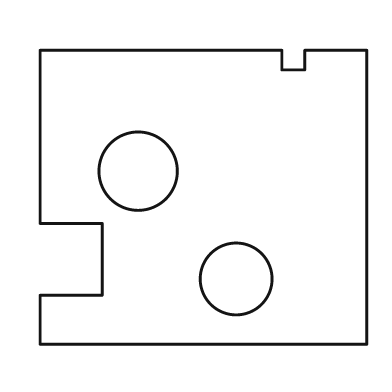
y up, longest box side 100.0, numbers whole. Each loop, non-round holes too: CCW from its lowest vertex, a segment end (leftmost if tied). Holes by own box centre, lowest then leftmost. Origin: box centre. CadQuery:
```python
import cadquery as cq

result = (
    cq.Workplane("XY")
    .moveTo(-50.0, -45.0)
    .lineTo(50.0, -45.0)
    .lineTo(50.0, 45.0)
    .lineTo(31.0, 45.0)
    .lineTo(31.0, 39.0)
    .lineTo(24.0, 39.0)
    .lineTo(24.0, 45.0)
    .lineTo(-50.0, 45.0)
    .lineTo(-50.0, -8.0)
    .lineTo(-31.0, -8.0)
    .lineTo(-31.0, -30.0)
    .lineTo(-50.0, -30.0)
    .close()
    .moveTo(10.0, -25.0)
    .circle(11.0)
    .moveTo(-20.0, 8.0)
    .circle(12.0)
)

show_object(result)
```